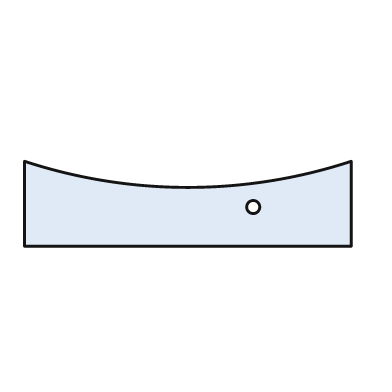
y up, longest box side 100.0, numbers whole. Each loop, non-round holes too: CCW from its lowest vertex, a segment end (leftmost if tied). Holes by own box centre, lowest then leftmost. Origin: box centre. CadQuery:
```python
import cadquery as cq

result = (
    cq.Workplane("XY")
    .moveTo(-50.0, -13.0)
    .lineTo(50.0, -13.0)
    .lineTo(50.0, 13.0)
    .threePointArc((0.0, 5.0), (-50.0, 13.0))
    .close()
    .moveTo(20.0, -1.0)
    .circle(2.0)
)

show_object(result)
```